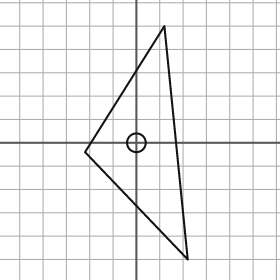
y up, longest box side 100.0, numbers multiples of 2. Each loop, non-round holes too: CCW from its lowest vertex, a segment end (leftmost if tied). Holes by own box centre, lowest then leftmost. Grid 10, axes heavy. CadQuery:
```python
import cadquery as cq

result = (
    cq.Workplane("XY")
    .moveTo(22.0, -50.0)
    .lineTo(12.0, 50.0)
    .lineTo(-22.0, -4.0)
    .close()
    .moveTo(0.0, 0.0)
    .circle(4.0)
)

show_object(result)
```